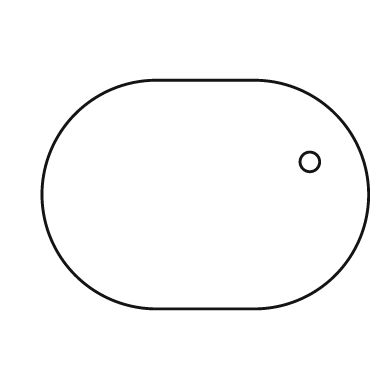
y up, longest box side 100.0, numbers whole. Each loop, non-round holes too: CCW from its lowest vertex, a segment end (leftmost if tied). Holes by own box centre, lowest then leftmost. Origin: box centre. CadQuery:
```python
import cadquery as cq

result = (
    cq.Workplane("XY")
    .moveTo(-15.0, -35.0)
    .lineTo(15.0, -35.0)
    .threePointArc((50.0, 0.0), (15.0, 35.0))
    .lineTo(-15.0, 35.0)
    .threePointArc((-50.0, 0.0), (-15.0, -35.0))
    .close()
    .moveTo(32.0, 10.0)
    .circle(3.0)
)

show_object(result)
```